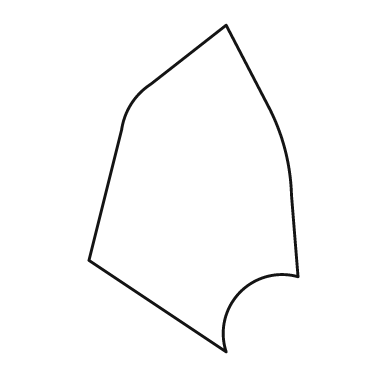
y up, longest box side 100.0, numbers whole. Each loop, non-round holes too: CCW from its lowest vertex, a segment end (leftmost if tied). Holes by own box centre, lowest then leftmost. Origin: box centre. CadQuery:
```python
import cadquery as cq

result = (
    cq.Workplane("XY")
    .moveTo(10.0, -50.0)
    .threePointArc((14.0, -32.0), (32.0, -27.0))
    .lineTo(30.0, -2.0)
    .threePointArc((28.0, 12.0), (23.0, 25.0))
    .lineTo(10.0, 50.0)
    .lineTo(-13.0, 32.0)
    .threePointArc((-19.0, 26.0), (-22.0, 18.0))
    .lineTo(-32.0, -22.0)
    .close()
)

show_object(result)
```